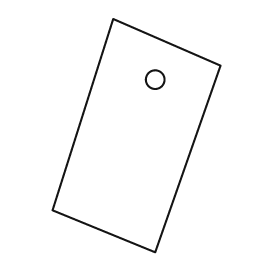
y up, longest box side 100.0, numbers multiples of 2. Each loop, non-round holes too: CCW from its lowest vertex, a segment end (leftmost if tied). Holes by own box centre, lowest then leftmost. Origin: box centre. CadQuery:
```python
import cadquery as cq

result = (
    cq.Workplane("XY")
    .moveTo(8.0, -50.0)
    .lineTo(36.0, 30.0)
    .lineTo(-10.0, 50.0)
    .lineTo(-36.0, -32.0)
    .close()
    .moveTo(8.0, 24.0)
    .circle(4.0)
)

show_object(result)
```